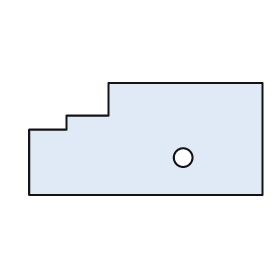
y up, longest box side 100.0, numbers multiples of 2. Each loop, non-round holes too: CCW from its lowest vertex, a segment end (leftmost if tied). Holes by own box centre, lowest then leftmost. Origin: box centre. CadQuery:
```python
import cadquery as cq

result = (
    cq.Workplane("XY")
    .moveTo(-50.0, -24.0)
    .lineTo(50.0, -24.0)
    .lineTo(50.0, 24.0)
    .lineTo(-16.0, 24.0)
    .lineTo(-16.0, 10.0)
    .lineTo(-34.0, 10.0)
    .lineTo(-34.0, 4.0)
    .lineTo(-50.0, 4.0)
    .close()
    .moveTo(16.0, -8.0)
    .circle(4.0)
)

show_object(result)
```